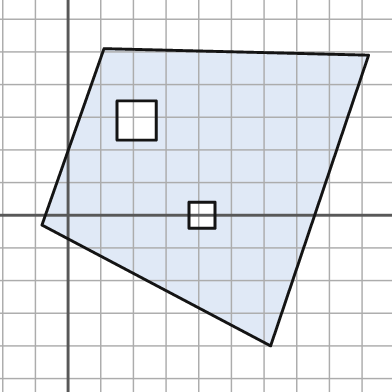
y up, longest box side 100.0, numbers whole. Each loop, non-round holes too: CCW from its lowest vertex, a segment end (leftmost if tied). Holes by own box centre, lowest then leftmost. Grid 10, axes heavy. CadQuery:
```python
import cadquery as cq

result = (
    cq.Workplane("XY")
    .moveTo(62.0, -40.0)
    .lineTo(92.0, 49.0)
    .lineTo(11.0, 51.0)
    .lineTo(-8.0, -3.0)
    .close()
    .moveTo(37.0, -4.0)
    .lineTo(45.0, -4.0)
    .lineTo(45.0, 4.0)
    .lineTo(37.0, 4.0)
    .close()
    .moveTo(15.0, 23.0)
    .lineTo(27.0, 23.0)
    .lineTo(27.0, 35.0)
    .lineTo(15.0, 35.0)
    .close()
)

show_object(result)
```